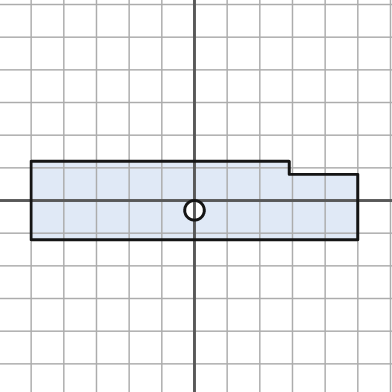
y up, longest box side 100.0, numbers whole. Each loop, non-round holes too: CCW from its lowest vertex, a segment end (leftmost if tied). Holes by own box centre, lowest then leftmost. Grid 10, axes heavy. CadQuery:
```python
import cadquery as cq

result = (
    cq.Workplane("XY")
    .moveTo(-50.0, -12.0)
    .lineTo(50.0, -12.0)
    .lineTo(50.0, 8.0)
    .lineTo(29.0, 8.0)
    .lineTo(29.0, 12.0)
    .lineTo(-50.0, 12.0)
    .close()
    .moveTo(0.0, -3.0)
    .circle(3.0)
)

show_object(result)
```